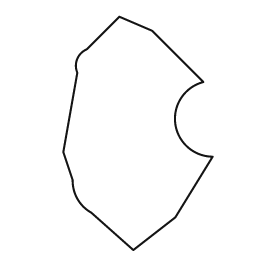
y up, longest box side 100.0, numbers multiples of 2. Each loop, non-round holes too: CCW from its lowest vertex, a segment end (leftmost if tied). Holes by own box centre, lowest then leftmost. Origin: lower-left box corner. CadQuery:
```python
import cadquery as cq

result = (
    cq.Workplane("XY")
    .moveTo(30.0, 0.0)
    .lineTo(48.0, 14.0)
    .lineTo(64.0, 40.0)
    .threePointArc((48.0, 54.0), (60.0, 72.0))
    .lineTo(38.0, 94.0)
    .lineTo(24.0, 100.0)
    .lineTo(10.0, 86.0)
    .threePointArc((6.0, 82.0), (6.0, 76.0))
    .lineTo(0.0, 42.0)
    .lineTo(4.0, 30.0)
    .threePointArc((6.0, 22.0), (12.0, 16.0))
    .close()
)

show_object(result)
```